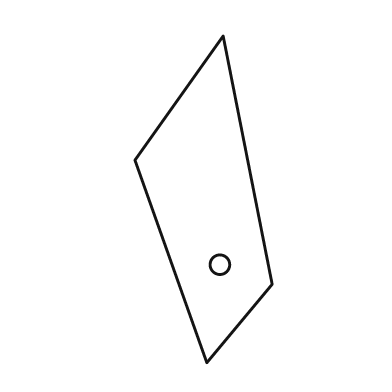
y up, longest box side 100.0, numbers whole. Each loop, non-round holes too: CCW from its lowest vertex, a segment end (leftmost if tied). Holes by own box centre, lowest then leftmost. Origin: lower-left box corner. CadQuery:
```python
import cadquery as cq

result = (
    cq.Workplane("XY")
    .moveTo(22.0, 0.0)
    .lineTo(42.0, 24.0)
    .lineTo(27.0, 100.0)
    .lineTo(0.0, 62.0)
    .close()
    .moveTo(26.0, 30.0)
    .circle(3.0)
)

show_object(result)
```